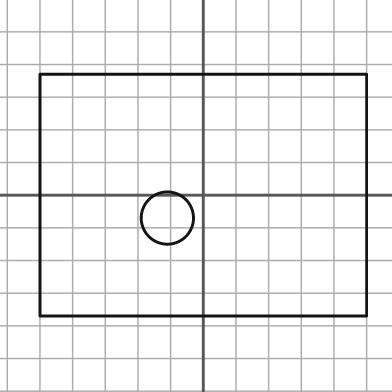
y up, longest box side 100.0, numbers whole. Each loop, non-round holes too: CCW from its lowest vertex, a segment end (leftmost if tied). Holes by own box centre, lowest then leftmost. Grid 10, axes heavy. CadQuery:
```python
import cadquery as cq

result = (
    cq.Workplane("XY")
    .moveTo(-50.0, -37.0)
    .lineTo(50.0, -37.0)
    .lineTo(50.0, 37.0)
    .lineTo(-50.0, 37.0)
    .close()
    .moveTo(-11.0, -7.0)
    .circle(8.0)
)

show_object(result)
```